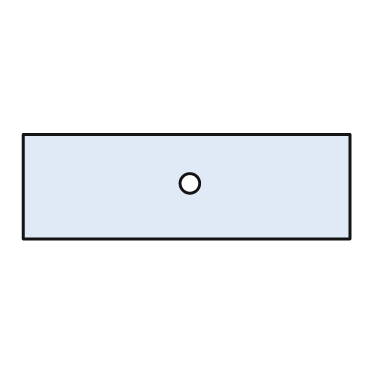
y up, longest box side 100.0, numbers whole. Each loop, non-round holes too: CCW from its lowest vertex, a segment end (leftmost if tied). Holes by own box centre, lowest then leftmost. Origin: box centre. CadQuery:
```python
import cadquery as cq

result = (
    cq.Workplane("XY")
    .moveTo(-50.0, -16.0)
    .lineTo(50.0, -16.0)
    .lineTo(50.0, 16.0)
    .lineTo(-50.0, 16.0)
    .close()
    .moveTo(1.0, 1.0)
    .circle(3.0)
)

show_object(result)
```